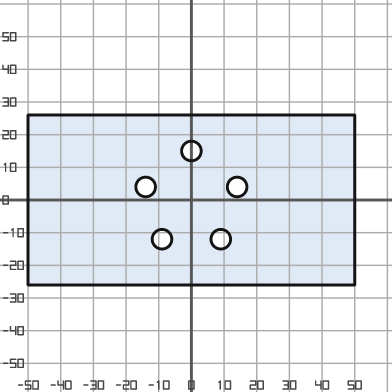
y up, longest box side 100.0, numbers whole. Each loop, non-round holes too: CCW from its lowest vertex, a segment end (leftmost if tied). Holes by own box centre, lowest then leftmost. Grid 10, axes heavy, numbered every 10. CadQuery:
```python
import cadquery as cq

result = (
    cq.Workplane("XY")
    .moveTo(-50.0, -26.0)
    .lineTo(50.0, -26.0)
    .lineTo(50.0, 26.0)
    .lineTo(-50.0, 26.0)
    .close()
    .moveTo(-9.0, -12.0)
    .circle(3.0)
    .moveTo(9.0, -12.0)
    .circle(3.0)
    .moveTo(-14.0, 4.0)
    .circle(3.0)
    .moveTo(14.0, 4.0)
    .circle(3.0)
    .moveTo(0.0, 15.0)
    .circle(3.0)
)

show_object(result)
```